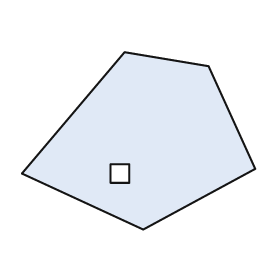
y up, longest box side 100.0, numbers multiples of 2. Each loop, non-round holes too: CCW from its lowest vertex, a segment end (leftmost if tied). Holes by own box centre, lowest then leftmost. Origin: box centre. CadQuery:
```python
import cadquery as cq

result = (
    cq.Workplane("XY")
    .moveTo(2.0, -38.0)
    .lineTo(50.0, -12.0)
    .lineTo(30.0, 32.0)
    .lineTo(-6.0, 38.0)
    .lineTo(-50.0, -14.0)
    .close()
    .moveTo(-12.0, -18.0)
    .lineTo(-4.0, -18.0)
    .lineTo(-4.0, -10.0)
    .lineTo(-12.0, -10.0)
    .close()
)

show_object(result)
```